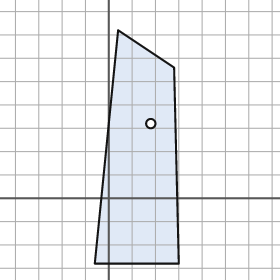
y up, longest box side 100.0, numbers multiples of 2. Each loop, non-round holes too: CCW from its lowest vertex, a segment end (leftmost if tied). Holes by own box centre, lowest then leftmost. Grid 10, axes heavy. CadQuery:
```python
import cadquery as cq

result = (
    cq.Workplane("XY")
    .moveTo(-6.0, -28.0)
    .lineTo(30.0, -28.0)
    .lineTo(28.0, 56.0)
    .lineTo(4.0, 72.0)
    .close()
    .moveTo(18.0, 32.0)
    .circle(2.0)
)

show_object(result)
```